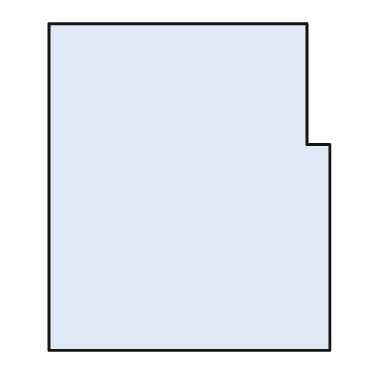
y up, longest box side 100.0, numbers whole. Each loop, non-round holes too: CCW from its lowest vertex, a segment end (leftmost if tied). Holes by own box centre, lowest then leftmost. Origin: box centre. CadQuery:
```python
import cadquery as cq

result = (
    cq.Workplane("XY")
    .moveTo(-43.0, -50.0)
    .lineTo(43.0, -50.0)
    .lineTo(43.0, 13.0)
    .lineTo(36.0, 13.0)
    .lineTo(36.0, 50.0)
    .lineTo(-43.0, 50.0)
    .close()
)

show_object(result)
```